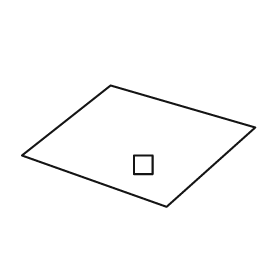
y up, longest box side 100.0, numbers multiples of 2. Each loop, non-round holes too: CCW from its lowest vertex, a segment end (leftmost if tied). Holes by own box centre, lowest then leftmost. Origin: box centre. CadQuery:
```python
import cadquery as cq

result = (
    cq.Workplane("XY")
    .moveTo(12.0, -26.0)
    .lineTo(50.0, 8.0)
    .lineTo(-12.0, 26.0)
    .lineTo(-50.0, -4.0)
    .close()
    .moveTo(-2.0, -12.0)
    .lineTo(6.0, -12.0)
    .lineTo(6.0, -4.0)
    .lineTo(-2.0, -4.0)
    .close()
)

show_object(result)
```